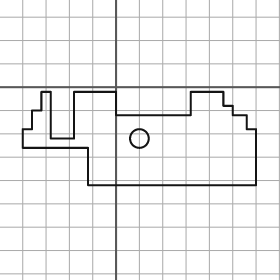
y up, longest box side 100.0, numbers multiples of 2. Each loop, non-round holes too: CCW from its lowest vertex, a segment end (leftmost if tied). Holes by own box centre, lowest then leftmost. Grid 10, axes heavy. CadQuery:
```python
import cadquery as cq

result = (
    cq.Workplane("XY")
    .moveTo(-12.0, -42.0)
    .lineTo(60.0, -42.0)
    .lineTo(60.0, -18.0)
    .lineTo(56.0, -18.0)
    .lineTo(56.0, -12.0)
    .lineTo(50.0, -12.0)
    .lineTo(50.0, -8.0)
    .lineTo(46.0, -8.0)
    .lineTo(46.0, -2.0)
    .lineTo(32.0, -2.0)
    .lineTo(32.0, -12.0)
    .lineTo(0.0, -12.0)
    .lineTo(0.0, -2.0)
    .lineTo(-18.0, -2.0)
    .lineTo(-18.0, -22.0)
    .lineTo(-28.0, -22.0)
    .lineTo(-28.0, -2.0)
    .lineTo(-32.0, -2.0)
    .lineTo(-32.0, -10.0)
    .lineTo(-36.0, -10.0)
    .lineTo(-36.0, -18.0)
    .lineTo(-40.0, -18.0)
    .lineTo(-40.0, -26.0)
    .lineTo(-12.0, -26.0)
    .close()
    .moveTo(10.0, -22.0)
    .circle(4.0)
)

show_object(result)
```